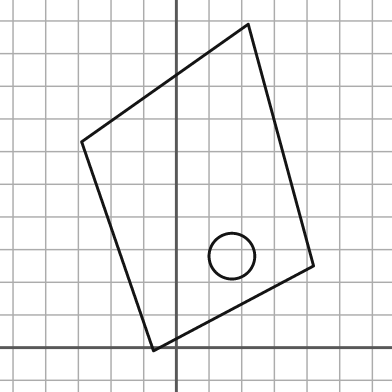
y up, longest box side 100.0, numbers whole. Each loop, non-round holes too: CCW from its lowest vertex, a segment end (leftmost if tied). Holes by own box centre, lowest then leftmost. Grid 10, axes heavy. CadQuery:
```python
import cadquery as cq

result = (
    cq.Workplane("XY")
    .moveTo(-7.0, -1.0)
    .lineTo(42.0, 25.0)
    .lineTo(22.0, 99.0)
    .lineTo(-29.0, 63.0)
    .close()
    .moveTo(17.0, 28.0)
    .circle(7.0)
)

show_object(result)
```